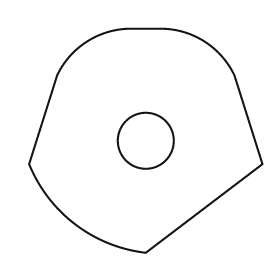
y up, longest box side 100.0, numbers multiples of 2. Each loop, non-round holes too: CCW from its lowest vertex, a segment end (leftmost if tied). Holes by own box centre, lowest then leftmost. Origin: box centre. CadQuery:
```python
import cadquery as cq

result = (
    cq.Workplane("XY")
    .moveTo(0.0, -48.0)
    .lineTo(50.0, -10.0)
    .lineTo(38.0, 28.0)
    .threePointArc((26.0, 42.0), (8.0, 48.0))
    .lineTo(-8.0, 48.0)
    .threePointArc((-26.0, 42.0), (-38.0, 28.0))
    .lineTo(-50.0, -10.0)
    .threePointArc((-30.0, -36.0), (0.0, -48.0))
    .close()
    .moveTo(0.0, 0.0)
    .circle(12.0)
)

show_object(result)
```